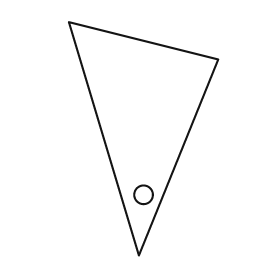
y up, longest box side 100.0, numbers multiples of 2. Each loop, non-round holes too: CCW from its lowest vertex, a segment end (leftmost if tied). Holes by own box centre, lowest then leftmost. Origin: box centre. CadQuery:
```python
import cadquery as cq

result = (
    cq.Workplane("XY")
    .moveTo(-2.0, -50.0)
    .lineTo(32.0, 34.0)
    .lineTo(-32.0, 50.0)
    .close()
    .moveTo(0.0, -24.0)
    .circle(4.0)
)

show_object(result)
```